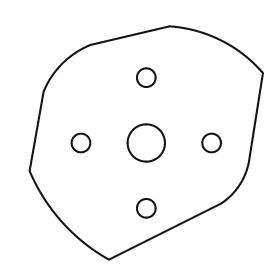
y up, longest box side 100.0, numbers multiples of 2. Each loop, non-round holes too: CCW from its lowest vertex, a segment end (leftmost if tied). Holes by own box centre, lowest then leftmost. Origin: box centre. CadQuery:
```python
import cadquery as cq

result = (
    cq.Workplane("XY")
    .moveTo(-16.0, -50.0)
    .lineTo(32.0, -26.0)
    .threePointArc((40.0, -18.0), (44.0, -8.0))
    .lineTo(50.0, 30.0)
    .threePointArc((32.0, 44.0), (10.0, 50.0))
    .lineTo(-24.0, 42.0)
    .threePointArc((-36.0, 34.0), (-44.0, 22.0))
    .lineTo(-50.0, -12.0)
    .threePointArc((-36.0, -34.0), (-16.0, -50.0))
    .close()
    .moveTo(0.0, -28.0)
    .circle(4.0)
    .moveTo(-28.0, 0.0)
    .circle(4.0)
    .moveTo(0.0, 0.0)
    .circle(8.0)
    .moveTo(28.0, 0.0)
    .circle(4.0)
    .moveTo(0.0, 28.0)
    .circle(4.0)
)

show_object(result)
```